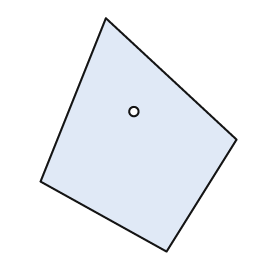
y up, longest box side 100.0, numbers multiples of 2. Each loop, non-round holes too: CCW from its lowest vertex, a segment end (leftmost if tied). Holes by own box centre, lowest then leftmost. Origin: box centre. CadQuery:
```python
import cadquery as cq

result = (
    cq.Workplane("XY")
    .moveTo(12.0, -50.0)
    .lineTo(42.0, -2.0)
    .lineTo(-14.0, 50.0)
    .lineTo(-42.0, -20.0)
    .close()
    .moveTo(-2.0, 10.0)
    .circle(2.0)
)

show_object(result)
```